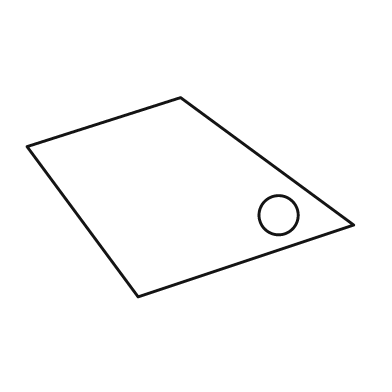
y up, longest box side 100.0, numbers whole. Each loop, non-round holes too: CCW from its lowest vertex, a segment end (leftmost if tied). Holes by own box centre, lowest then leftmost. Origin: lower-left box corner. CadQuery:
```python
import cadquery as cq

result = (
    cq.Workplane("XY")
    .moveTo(34.0, 0.0)
    .lineTo(100.0, 22.0)
    .lineTo(47.0, 61.0)
    .lineTo(0.0, 46.0)
    .close()
    .moveTo(77.0, 25.0)
    .circle(6.0)
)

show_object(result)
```